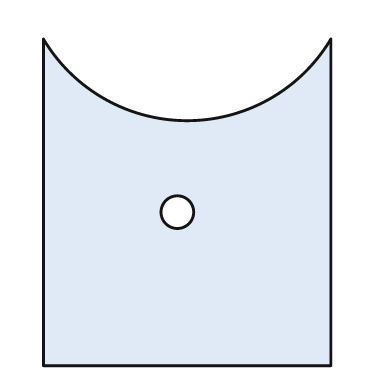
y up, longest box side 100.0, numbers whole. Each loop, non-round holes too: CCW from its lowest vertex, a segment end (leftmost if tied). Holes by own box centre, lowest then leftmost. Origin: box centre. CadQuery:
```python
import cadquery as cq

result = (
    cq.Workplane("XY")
    .moveTo(-44.0, -50.0)
    .lineTo(44.0, -50.0)
    .lineTo(44.0, 50.0)
    .threePointArc((0.0, 25.0), (-44.0, 50.0))
    .close()
    .moveTo(-3.0, -3.0)
    .circle(5.0)
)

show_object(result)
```